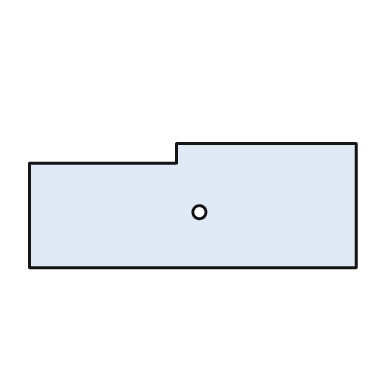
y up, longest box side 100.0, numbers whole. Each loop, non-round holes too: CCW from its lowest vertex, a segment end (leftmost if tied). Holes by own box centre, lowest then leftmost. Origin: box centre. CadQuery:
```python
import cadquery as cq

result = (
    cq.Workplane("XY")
    .moveTo(-50.0, -19.0)
    .lineTo(50.0, -19.0)
    .lineTo(50.0, 19.0)
    .lineTo(-5.0, 19.0)
    .lineTo(-5.0, 13.0)
    .lineTo(-50.0, 13.0)
    .close()
    .moveTo(2.0, -2.0)
    .circle(2.0)
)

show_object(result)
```